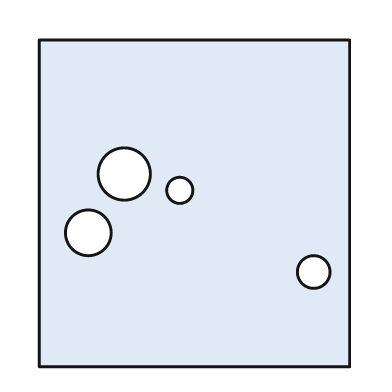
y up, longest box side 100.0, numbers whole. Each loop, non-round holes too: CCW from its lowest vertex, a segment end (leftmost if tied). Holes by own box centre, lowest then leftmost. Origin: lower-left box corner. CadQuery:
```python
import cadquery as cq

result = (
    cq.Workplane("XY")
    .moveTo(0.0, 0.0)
    .lineTo(95.0, 0.0)
    .lineTo(95.0, 100.0)
    .lineTo(0.0, 100.0)
    .close()
    .moveTo(84.0, 29.0)
    .circle(5.0)
    .moveTo(15.0, 41.0)
    .circle(7.0)
    .moveTo(43.0, 54.0)
    .circle(4.0)
    .moveTo(26.0, 59.0)
    .circle(8.0)
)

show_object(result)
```